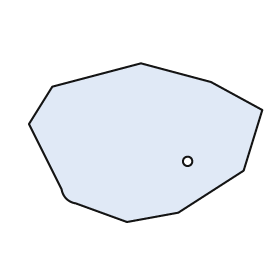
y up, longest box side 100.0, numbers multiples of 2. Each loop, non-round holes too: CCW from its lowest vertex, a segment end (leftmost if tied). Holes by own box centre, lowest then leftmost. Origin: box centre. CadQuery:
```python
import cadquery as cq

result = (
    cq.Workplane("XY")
    .moveTo(-8.0, -34.0)
    .lineTo(14.0, -30.0)
    .lineTo(42.0, -12.0)
    .lineTo(50.0, 14.0)
    .lineTo(28.0, 26.0)
    .lineTo(-2.0, 34.0)
    .lineTo(-40.0, 24.0)
    .lineTo(-50.0, 8.0)
    .lineTo(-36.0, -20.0)
    .threePointArc((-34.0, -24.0), (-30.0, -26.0))
    .close()
    .moveTo(18.0, -8.0)
    .circle(2.0)
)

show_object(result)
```